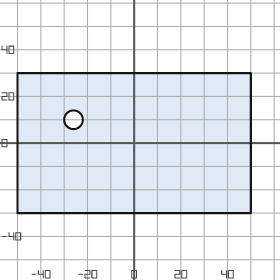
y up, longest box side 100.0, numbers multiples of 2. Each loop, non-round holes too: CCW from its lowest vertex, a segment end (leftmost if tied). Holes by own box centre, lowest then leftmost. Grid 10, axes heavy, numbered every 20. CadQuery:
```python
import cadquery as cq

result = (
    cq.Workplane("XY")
    .moveTo(-50.0, -30.0)
    .lineTo(50.0, -30.0)
    .lineTo(50.0, 30.0)
    .lineTo(-50.0, 30.0)
    .close()
    .moveTo(-26.0, 10.0)
    .circle(4.0)
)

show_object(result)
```